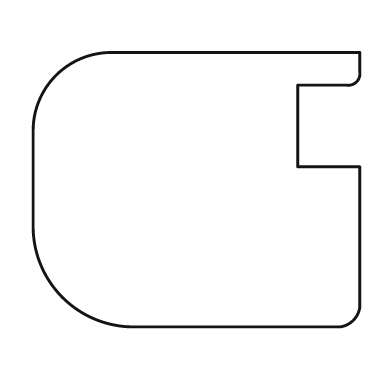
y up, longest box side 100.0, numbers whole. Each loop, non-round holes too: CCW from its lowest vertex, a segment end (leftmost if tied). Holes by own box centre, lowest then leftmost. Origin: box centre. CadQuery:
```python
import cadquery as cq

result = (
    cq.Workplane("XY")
    .moveTo(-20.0, -42.0)
    .lineTo(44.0, -42.0)
    .threePointArc((48.0, -40.0), (50.0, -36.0))
    .lineTo(50.0, 7.0)
    .lineTo(31.0, 7.0)
    .lineTo(31.0, 32.0)
    .lineTo(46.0, 32.0)
    .threePointArc((49.0, 33.0), (50.0, 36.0))
    .lineTo(50.0, 42.0)
    .lineTo(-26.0, 42.0)
    .threePointArc((-43.0, 35.0), (-50.0, 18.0))
    .lineTo(-50.0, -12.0)
    .threePointArc((-41.0, -33.0), (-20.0, -42.0))
    .close()
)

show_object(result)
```